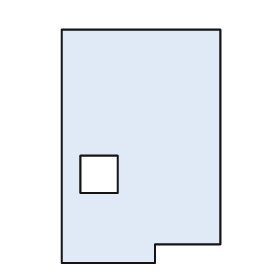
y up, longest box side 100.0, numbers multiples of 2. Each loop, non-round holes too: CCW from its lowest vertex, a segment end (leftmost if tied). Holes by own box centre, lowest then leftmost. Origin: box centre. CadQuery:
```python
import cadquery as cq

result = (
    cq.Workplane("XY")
    .moveTo(-34.0, -50.0)
    .lineTo(6.0, -50.0)
    .lineTo(6.0, -42.0)
    .lineTo(34.0, -42.0)
    .lineTo(34.0, 50.0)
    .lineTo(-34.0, 50.0)
    .close()
    .moveTo(-26.0, -20.0)
    .lineTo(-10.0, -20.0)
    .lineTo(-10.0, -4.0)
    .lineTo(-26.0, -4.0)
    .close()
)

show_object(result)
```